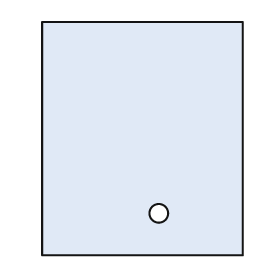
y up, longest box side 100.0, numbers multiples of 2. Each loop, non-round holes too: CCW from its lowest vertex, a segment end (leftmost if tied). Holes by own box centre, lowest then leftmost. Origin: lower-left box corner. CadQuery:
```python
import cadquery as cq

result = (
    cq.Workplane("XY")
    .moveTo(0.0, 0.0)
    .lineTo(86.0, 0.0)
    .lineTo(86.0, 100.0)
    .lineTo(0.0, 100.0)
    .close()
    .moveTo(50.0, 18.0)
    .circle(4.0)
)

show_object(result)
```